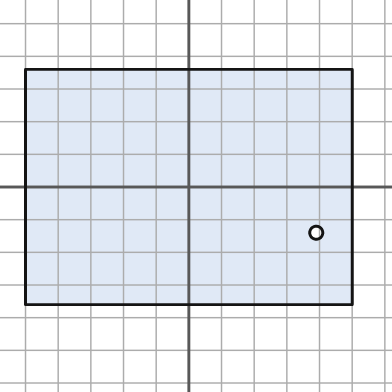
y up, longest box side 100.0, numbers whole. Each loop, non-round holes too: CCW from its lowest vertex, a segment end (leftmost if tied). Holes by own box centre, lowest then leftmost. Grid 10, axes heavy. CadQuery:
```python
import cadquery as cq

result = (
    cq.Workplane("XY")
    .moveTo(-50.0, -36.0)
    .lineTo(50.0, -36.0)
    .lineTo(50.0, 36.0)
    .lineTo(-50.0, 36.0)
    .close()
    .moveTo(39.0, -14.0)
    .circle(2.0)
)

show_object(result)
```